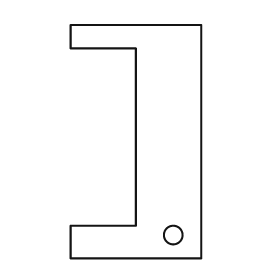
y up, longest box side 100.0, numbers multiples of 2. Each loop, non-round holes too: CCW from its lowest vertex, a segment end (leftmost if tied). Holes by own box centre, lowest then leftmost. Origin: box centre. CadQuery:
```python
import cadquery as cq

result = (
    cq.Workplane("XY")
    .moveTo(-28.0, -50.0)
    .lineTo(28.0, -50.0)
    .lineTo(28.0, 50.0)
    .lineTo(-28.0, 50.0)
    .lineTo(-28.0, 40.0)
    .lineTo(0.0, 40.0)
    .lineTo(0.0, -36.0)
    .lineTo(-28.0, -36.0)
    .close()
    .moveTo(16.0, -40.0)
    .circle(4.0)
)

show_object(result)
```